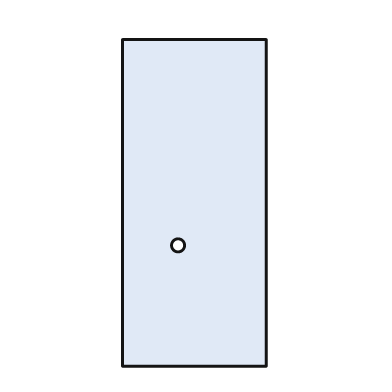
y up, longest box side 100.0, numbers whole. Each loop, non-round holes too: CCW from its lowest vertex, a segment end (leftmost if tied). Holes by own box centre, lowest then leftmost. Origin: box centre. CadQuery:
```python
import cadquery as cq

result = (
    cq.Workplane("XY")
    .moveTo(-22.0, -50.0)
    .lineTo(22.0, -50.0)
    .lineTo(22.0, 50.0)
    .lineTo(-22.0, 50.0)
    .close()
    .moveTo(-5.0, -13.0)
    .circle(2.0)
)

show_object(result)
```